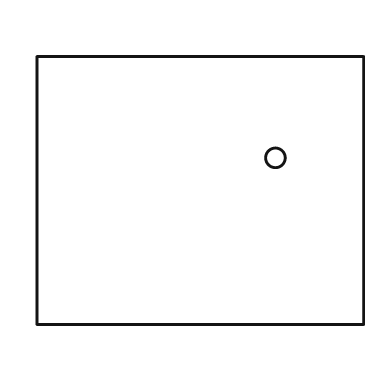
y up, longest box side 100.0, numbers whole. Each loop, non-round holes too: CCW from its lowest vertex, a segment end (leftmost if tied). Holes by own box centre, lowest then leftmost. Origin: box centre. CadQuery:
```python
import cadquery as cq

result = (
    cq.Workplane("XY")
    .moveTo(-50.0, -41.0)
    .lineTo(50.0, -41.0)
    .lineTo(50.0, 41.0)
    .lineTo(-50.0, 41.0)
    .close()
    .moveTo(23.0, 10.0)
    .circle(3.0)
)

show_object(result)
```